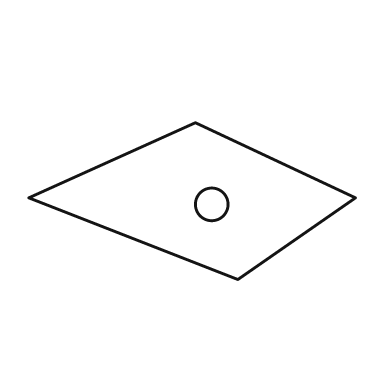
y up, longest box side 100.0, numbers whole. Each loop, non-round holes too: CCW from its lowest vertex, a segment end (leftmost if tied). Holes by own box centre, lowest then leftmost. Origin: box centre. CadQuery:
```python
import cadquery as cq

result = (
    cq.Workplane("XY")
    .moveTo(14.0, -24.0)
    .lineTo(50.0, 1.0)
    .lineTo(1.0, 24.0)
    .lineTo(-50.0, 1.0)
    .close()
    .moveTo(6.0, -1.0)
    .circle(5.0)
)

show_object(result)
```